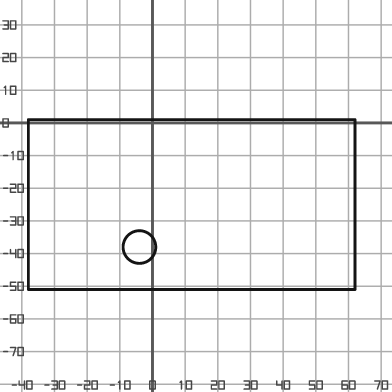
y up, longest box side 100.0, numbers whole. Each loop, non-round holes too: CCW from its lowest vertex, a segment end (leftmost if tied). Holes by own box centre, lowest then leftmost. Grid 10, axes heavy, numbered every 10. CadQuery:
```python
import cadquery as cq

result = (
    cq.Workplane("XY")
    .moveTo(-38.0, -51.0)
    .lineTo(62.0, -51.0)
    .lineTo(62.0, 1.0)
    .lineTo(-38.0, 1.0)
    .close()
    .moveTo(-4.0, -38.0)
    .circle(5.0)
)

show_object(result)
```